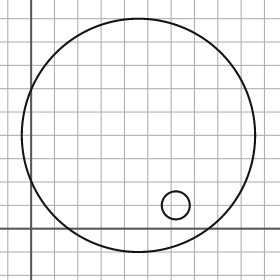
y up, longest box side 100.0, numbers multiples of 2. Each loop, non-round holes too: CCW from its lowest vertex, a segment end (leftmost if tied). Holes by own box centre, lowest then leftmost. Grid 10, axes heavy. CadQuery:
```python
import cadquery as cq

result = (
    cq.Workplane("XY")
    .moveTo(46.0, 40.0)
    .circle(50.0)
    .moveTo(62.0, 10.0)
    .circle(6.0)
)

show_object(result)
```